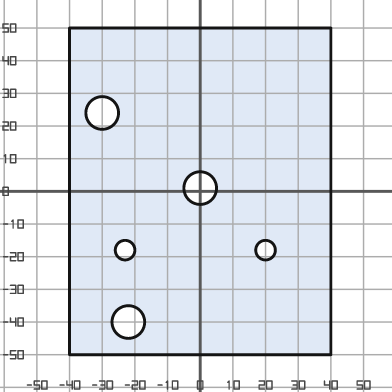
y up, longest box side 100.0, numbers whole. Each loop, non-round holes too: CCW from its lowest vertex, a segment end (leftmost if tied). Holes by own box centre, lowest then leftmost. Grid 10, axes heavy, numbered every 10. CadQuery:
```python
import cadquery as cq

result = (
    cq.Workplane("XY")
    .moveTo(-40.0, -50.0)
    .lineTo(40.0, -50.0)
    .lineTo(40.0, 50.0)
    .lineTo(-40.0, 50.0)
    .close()
    .moveTo(-22.0, -40.0)
    .circle(5.0)
    .moveTo(-23.0, -18.0)
    .circle(3.0)
    .moveTo(20.0, -18.0)
    .circle(3.0)
    .moveTo(0.0, 1.0)
    .circle(5.0)
    .moveTo(-30.0, 24.0)
    .circle(5.0)
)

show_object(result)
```